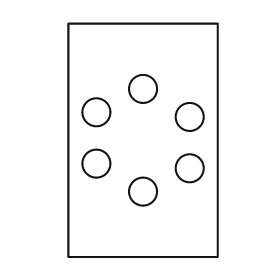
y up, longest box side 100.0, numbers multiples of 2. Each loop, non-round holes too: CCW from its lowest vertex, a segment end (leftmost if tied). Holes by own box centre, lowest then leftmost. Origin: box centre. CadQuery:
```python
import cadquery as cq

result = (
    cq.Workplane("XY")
    .moveTo(-32.0, -50.0)
    .lineTo(32.0, -50.0)
    .lineTo(32.0, 50.0)
    .lineTo(-32.0, 50.0)
    .close()
    .moveTo(0.0, -22.0)
    .circle(6.0)
    .moveTo(20.0, -12.0)
    .circle(6.0)
    .moveTo(-20.0, -10.0)
    .circle(6.0)
    .moveTo(20.0, 10.0)
    .circle(6.0)
    .moveTo(-20.0, 12.0)
    .circle(6.0)
    .moveTo(0.0, 22.0)
    .circle(6.0)
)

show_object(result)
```